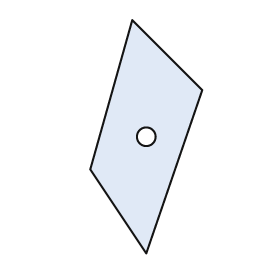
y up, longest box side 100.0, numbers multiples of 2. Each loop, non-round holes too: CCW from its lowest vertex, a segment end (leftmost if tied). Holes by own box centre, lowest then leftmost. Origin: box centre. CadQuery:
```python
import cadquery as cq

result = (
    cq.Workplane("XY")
    .moveTo(0.0, -50.0)
    .lineTo(24.0, 20.0)
    .lineTo(-6.0, 50.0)
    .lineTo(-24.0, -14.0)
    .close()
    .moveTo(0.0, 0.0)
    .circle(4.0)
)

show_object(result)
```